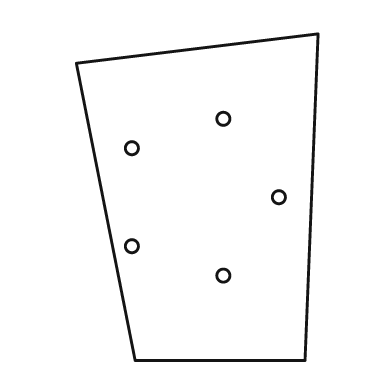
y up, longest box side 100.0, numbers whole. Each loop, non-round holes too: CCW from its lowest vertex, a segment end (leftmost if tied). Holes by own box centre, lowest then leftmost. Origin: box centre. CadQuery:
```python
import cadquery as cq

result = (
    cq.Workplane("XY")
    .moveTo(-19.0, -50.0)
    .lineTo(33.0, -50.0)
    .lineTo(37.0, 50.0)
    .lineTo(-37.0, 41.0)
    .close()
    .moveTo(8.0, -24.0)
    .circle(2.0)
    .moveTo(-20.0, -15.0)
    .circle(2.0)
    .moveTo(25.0, 0.0)
    .circle(2.0)
    .moveTo(-20.0, 15.0)
    .circle(2.0)
    .moveTo(8.0, 24.0)
    .circle(2.0)
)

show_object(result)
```